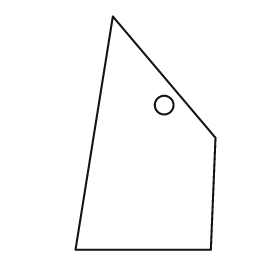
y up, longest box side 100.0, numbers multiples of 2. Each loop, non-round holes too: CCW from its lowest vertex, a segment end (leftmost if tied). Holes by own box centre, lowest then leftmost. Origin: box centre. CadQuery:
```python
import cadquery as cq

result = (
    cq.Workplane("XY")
    .moveTo(-30.0, -50.0)
    .lineTo(28.0, -50.0)
    .lineTo(30.0, -2.0)
    .lineTo(-14.0, 50.0)
    .close()
    .moveTo(8.0, 12.0)
    .circle(4.0)
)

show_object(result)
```